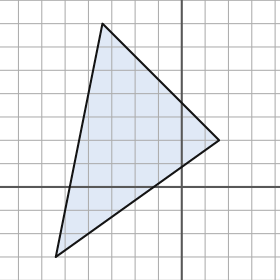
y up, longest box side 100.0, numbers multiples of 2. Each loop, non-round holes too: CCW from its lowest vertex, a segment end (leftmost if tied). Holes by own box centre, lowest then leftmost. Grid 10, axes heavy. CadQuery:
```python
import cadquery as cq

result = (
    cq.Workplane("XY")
    .moveTo(-54.0, -30.0)
    .lineTo(16.0, 20.0)
    .lineTo(-34.0, 70.0)
    .close()
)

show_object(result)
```